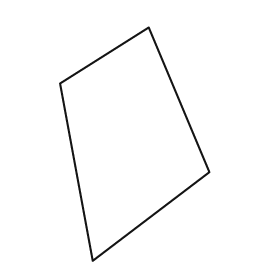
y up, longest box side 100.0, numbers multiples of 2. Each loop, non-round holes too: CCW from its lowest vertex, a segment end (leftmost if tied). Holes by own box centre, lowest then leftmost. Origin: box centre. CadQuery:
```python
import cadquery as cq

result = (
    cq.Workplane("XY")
    .moveTo(-18.0, -50.0)
    .lineTo(32.0, -12.0)
    .lineTo(6.0, 50.0)
    .lineTo(-32.0, 26.0)
    .close()
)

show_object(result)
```